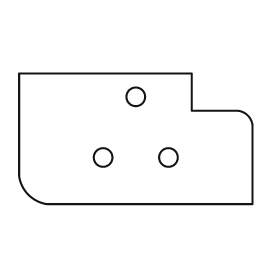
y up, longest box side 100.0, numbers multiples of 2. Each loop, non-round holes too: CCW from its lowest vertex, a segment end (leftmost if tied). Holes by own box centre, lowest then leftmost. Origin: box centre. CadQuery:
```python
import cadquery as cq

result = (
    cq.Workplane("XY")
    .moveTo(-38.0, -28.0)
    .lineTo(50.0, -28.0)
    .lineTo(50.0, 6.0)
    .threePointArc((48.0, 10.0), (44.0, 12.0))
    .lineTo(24.0, 12.0)
    .lineTo(24.0, 28.0)
    .lineTo(-50.0, 28.0)
    .lineTo(-50.0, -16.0)
    .threePointArc((-46.0, -24.0), (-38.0, -28.0))
    .close()
    .moveTo(-14.0, -8.0)
    .circle(4.0)
    .moveTo(14.0, -8.0)
    .circle(4.0)
    .moveTo(0.0, 18.0)
    .circle(4.0)
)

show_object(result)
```